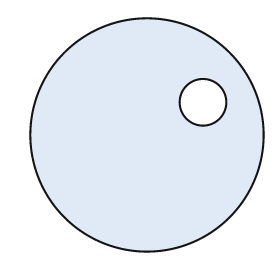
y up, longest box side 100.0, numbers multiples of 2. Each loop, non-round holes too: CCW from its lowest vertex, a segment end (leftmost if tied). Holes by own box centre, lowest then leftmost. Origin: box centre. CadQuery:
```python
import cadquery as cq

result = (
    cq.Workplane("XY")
    .moveTo(0.0, 0.0)
    .circle(50.0)
    .moveTo(24.0, 14.0)
    .circle(10.0)
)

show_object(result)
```